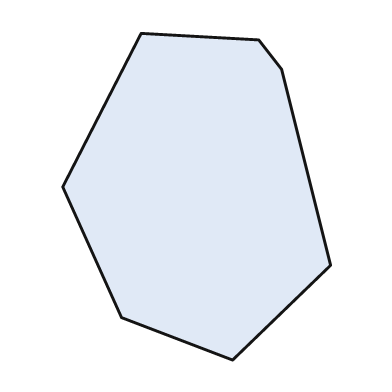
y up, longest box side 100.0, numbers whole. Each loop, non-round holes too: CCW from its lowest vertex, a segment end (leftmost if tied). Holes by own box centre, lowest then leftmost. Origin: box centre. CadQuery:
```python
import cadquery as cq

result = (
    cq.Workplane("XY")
    .moveTo(11.0, -50.0)
    .lineTo(41.0, -21.0)
    .lineTo(26.0, 39.0)
    .lineTo(19.0, 48.0)
    .lineTo(-17.0, 50.0)
    .lineTo(-41.0, 3.0)
    .lineTo(-23.0, -37.0)
    .close()
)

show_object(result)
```